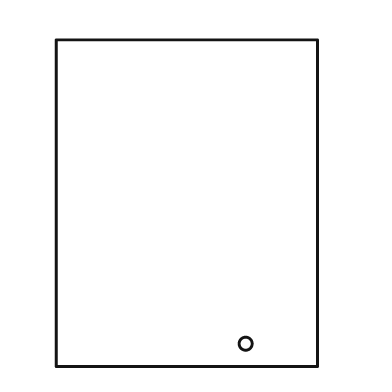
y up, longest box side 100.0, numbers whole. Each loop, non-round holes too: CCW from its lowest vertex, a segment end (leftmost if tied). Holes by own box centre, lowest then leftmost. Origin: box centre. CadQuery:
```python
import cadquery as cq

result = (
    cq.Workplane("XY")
    .moveTo(-40.0, -50.0)
    .lineTo(40.0, -50.0)
    .lineTo(40.0, 50.0)
    .lineTo(-40.0, 50.0)
    .close()
    .moveTo(18.0, -43.0)
    .circle(2.0)
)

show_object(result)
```